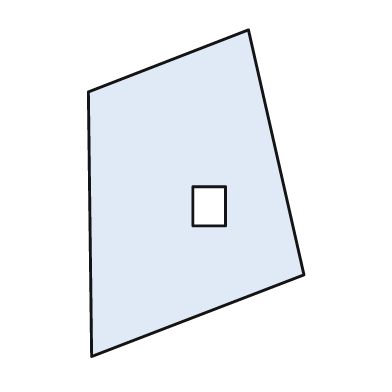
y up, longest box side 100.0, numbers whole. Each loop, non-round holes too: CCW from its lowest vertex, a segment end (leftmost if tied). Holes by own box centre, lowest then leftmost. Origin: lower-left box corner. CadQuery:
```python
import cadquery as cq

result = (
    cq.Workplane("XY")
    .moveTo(1.0, 0.0)
    .lineTo(66.0, 25.0)
    .lineTo(49.0, 100.0)
    .lineTo(0.0, 81.0)
    .close()
    .moveTo(32.0, 40.0)
    .lineTo(42.0, 40.0)
    .lineTo(42.0, 52.0)
    .lineTo(32.0, 52.0)
    .close()
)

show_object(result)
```